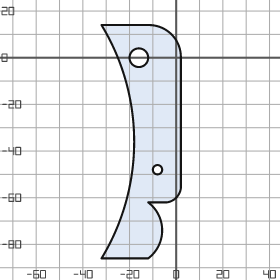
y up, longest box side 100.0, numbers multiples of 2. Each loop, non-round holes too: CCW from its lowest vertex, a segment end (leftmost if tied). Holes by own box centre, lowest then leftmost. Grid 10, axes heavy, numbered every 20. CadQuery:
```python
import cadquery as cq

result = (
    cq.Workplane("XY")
    .moveTo(-32.0, -86.0)
    .lineTo(-12.0, -86.0)
    .threePointArc((-6.0, -74.0), (-12.0, -62.0))
    .lineTo(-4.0, -62.0)
    .threePointArc((0.0, -60.0), (2.0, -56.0))
    .lineTo(2.0, 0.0)
    .threePointArc((-2.0, 10.0), (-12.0, 14.0))
    .lineTo(-32.0, 14.0)
    .threePointArc((-18.0, -36.0), (-32.0, -86.0))
    .close()
    .moveTo(-8.0, -48.0)
    .circle(2.0)
    .moveTo(-16.0, 0.0)
    .circle(4.0)
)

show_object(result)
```